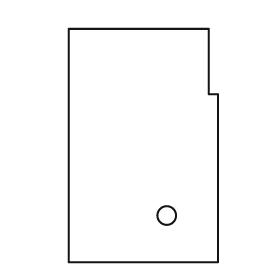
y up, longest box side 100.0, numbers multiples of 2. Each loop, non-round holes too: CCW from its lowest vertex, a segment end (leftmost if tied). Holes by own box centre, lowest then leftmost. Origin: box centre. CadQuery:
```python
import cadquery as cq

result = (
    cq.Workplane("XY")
    .moveTo(-32.0, -50.0)
    .lineTo(32.0, -50.0)
    .lineTo(32.0, 22.0)
    .lineTo(28.0, 22.0)
    .lineTo(28.0, 50.0)
    .lineTo(-32.0, 50.0)
    .close()
    .moveTo(10.0, -30.0)
    .circle(4.0)
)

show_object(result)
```